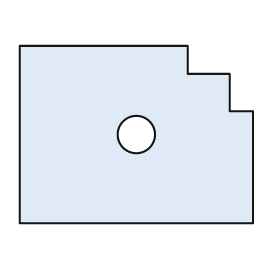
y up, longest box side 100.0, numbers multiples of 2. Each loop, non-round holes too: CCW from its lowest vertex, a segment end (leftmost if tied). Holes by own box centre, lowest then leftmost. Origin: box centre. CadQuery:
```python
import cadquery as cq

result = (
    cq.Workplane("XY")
    .moveTo(-50.0, -38.0)
    .lineTo(50.0, -38.0)
    .lineTo(50.0, 10.0)
    .lineTo(40.0, 10.0)
    .lineTo(40.0, 26.0)
    .lineTo(22.0, 26.0)
    .lineTo(22.0, 38.0)
    .lineTo(-50.0, 38.0)
    .close()
    .moveTo(0.0, 0.0)
    .circle(8.0)
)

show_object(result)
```